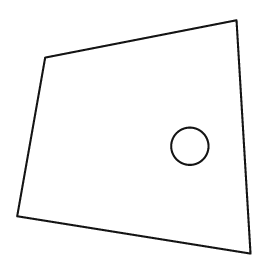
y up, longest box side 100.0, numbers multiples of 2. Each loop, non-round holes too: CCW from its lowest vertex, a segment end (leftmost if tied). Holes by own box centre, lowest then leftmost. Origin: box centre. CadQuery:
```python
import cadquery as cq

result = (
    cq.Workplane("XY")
    .moveTo(50.0, -50.0)
    .lineTo(44.0, 50.0)
    .lineTo(-38.0, 34.0)
    .lineTo(-50.0, -34.0)
    .close()
    .moveTo(24.0, -4.0)
    .circle(8.0)
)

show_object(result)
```